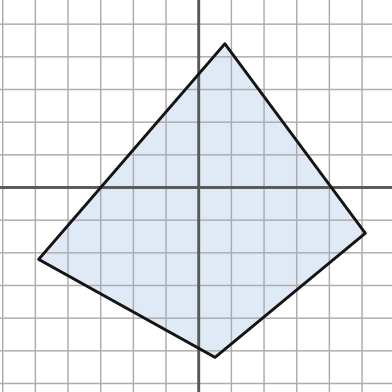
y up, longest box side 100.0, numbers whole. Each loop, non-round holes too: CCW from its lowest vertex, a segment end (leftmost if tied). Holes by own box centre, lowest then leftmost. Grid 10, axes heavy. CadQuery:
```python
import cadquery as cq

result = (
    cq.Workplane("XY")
    .moveTo(5.0, -52.0)
    .lineTo(51.0, -14.0)
    .lineTo(8.0, 44.0)
    .lineTo(-49.0, -22.0)
    .close()
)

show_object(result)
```